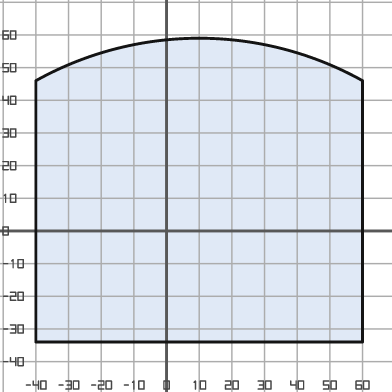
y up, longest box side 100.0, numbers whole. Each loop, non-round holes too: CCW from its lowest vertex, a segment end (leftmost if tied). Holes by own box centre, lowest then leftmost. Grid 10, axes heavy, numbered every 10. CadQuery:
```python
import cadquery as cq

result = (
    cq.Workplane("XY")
    .moveTo(-40.0, -34.0)
    .lineTo(60.0, -34.0)
    .lineTo(60.0, 46.0)
    .threePointArc((10.0, 59.0), (-40.0, 46.0))
    .close()
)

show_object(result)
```